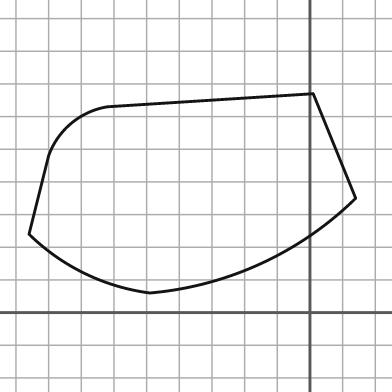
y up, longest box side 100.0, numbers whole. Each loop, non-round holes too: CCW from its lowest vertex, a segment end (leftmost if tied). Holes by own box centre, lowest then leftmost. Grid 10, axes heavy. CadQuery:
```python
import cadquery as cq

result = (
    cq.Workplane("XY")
    .moveTo(-49.0, 6.0)
    .threePointArc((-15.0, 15.0), (14.0, 35.0))
    .lineTo(1.0, 67.0)
    .lineTo(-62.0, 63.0)
    .threePointArc((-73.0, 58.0), (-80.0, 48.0))
    .lineTo(-86.0, 24.0)
    .threePointArc((-69.0, 12.0), (-49.0, 6.0))
    .close()
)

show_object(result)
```